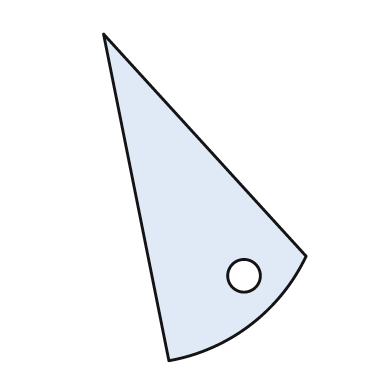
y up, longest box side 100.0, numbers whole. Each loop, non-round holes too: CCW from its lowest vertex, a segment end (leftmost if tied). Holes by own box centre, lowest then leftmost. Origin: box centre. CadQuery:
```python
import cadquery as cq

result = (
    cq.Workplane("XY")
    .moveTo(-11.0, -50.0)
    .threePointArc((14.0, -39.0), (31.0, -18.0))
    .lineTo(-31.0, 50.0)
    .close()
    .moveTo(12.0, -24.0)
    .circle(5.0)
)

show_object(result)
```